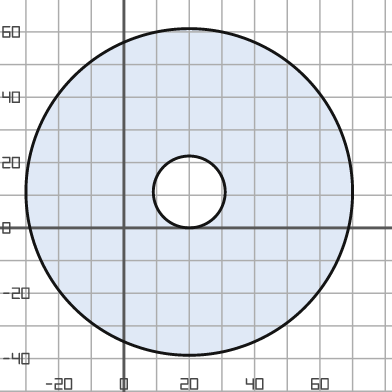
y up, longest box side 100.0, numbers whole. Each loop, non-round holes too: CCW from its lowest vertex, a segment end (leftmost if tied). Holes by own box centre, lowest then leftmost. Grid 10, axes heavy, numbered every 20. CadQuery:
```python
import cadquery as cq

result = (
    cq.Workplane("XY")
    .moveTo(20.0, 11.0)
    .circle(50.0)
    .moveTo(20.0, 11.0)
    .circle(11.0)
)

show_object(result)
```